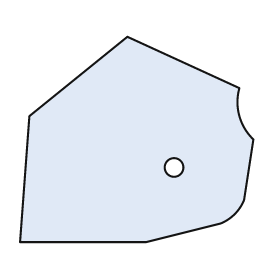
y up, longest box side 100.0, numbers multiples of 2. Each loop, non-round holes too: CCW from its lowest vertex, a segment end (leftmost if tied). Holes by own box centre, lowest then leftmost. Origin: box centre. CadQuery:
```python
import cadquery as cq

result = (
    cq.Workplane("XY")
    .moveTo(-50.0, -44.0)
    .lineTo(4.0, -44.0)
    .lineTo(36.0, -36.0)
    .threePointArc((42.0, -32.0), (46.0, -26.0))
    .lineTo(50.0, 0.0)
    .threePointArc((44.0, 10.0), (44.0, 22.0))
    .lineTo(-4.0, 44.0)
    .lineTo(-46.0, 10.0)
    .close()
    .moveTo(16.0, -12.0)
    .circle(4.0)
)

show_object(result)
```